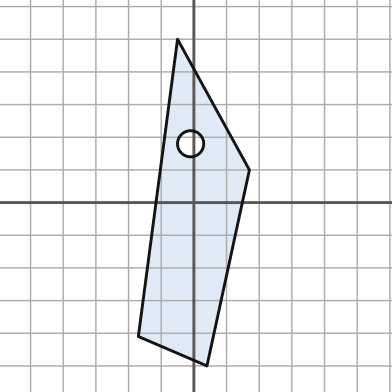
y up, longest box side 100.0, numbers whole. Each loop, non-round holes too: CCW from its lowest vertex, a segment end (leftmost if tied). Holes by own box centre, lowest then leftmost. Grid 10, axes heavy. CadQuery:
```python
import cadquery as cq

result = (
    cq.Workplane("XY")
    .moveTo(4.0, -50.0)
    .lineTo(17.0, 10.0)
    .lineTo(-5.0, 50.0)
    .lineTo(-17.0, -41.0)
    .close()
    .moveTo(-1.0, 18.0)
    .circle(4.0)
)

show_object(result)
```